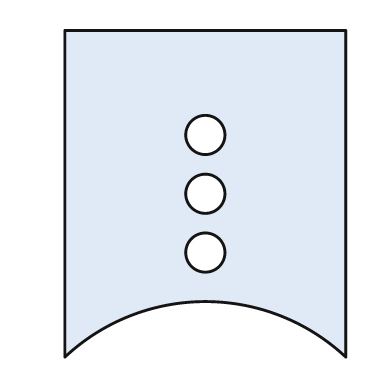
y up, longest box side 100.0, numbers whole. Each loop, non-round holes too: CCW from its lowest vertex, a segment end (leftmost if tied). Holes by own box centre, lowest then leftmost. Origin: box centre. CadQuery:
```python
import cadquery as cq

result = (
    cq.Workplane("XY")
    .moveTo(-43.0, -50.0)
    .threePointArc((0.0, -33.0), (43.0, -50.0))
    .lineTo(43.0, 50.0)
    .lineTo(-43.0, 50.0)
    .close()
    .moveTo(0.0, -18.0)
    .circle(6.0)
    .moveTo(0.0, 0.0)
    .circle(6.0)
    .moveTo(0.0, 18.0)
    .circle(6.0)
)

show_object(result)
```